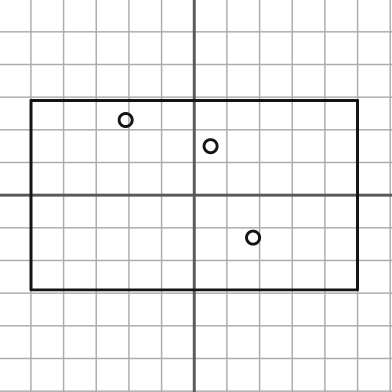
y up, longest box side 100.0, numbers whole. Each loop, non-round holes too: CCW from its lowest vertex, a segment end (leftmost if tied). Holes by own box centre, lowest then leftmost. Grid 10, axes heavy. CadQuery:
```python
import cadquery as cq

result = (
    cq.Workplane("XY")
    .moveTo(-50.0, -29.0)
    .lineTo(50.0, -29.0)
    .lineTo(50.0, 29.0)
    .lineTo(-50.0, 29.0)
    .close()
    .moveTo(18.0, -13.0)
    .circle(2.0)
    .moveTo(5.0, 15.0)
    .circle(2.0)
    .moveTo(-21.0, 23.0)
    .circle(2.0)
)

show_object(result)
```